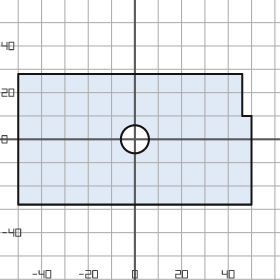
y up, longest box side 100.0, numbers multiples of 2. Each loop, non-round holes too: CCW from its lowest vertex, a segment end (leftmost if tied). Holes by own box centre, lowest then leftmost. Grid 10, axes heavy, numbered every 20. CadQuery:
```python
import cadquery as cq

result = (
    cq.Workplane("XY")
    .moveTo(-50.0, -28.0)
    .lineTo(50.0, -28.0)
    .lineTo(50.0, 10.0)
    .lineTo(46.0, 10.0)
    .lineTo(46.0, 28.0)
    .lineTo(-50.0, 28.0)
    .close()
    .moveTo(0.0, 0.0)
    .circle(6.0)
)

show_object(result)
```